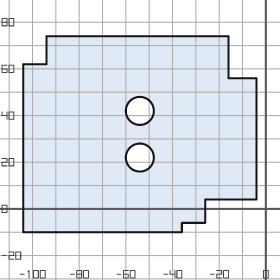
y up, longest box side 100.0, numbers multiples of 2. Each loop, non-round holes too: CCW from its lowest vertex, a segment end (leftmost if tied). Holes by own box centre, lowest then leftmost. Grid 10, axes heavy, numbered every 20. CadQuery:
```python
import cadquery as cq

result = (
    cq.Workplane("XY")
    .moveTo(-104.0, -10.0)
    .lineTo(-36.0, -10.0)
    .lineTo(-36.0, -6.0)
    .lineTo(-26.0, -6.0)
    .lineTo(-26.0, 4.0)
    .lineTo(-4.0, 4.0)
    .lineTo(-4.0, 56.0)
    .lineTo(-16.0, 56.0)
    .lineTo(-16.0, 74.0)
    .lineTo(-94.0, 74.0)
    .lineTo(-94.0, 62.0)
    .lineTo(-104.0, 62.0)
    .close()
    .moveTo(-54.0, 22.0)
    .circle(6.0)
    .moveTo(-54.0, 42.0)
    .circle(6.0)
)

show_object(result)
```